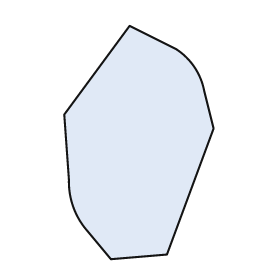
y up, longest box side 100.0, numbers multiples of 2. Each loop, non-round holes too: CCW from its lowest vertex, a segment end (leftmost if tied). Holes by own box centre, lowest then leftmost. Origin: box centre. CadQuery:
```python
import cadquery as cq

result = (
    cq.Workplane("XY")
    .moveTo(-12.0, -50.0)
    .lineTo(12.0, -48.0)
    .lineTo(32.0, 6.0)
    .lineTo(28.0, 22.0)
    .threePointArc((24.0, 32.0), (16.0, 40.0))
    .lineTo(-4.0, 50.0)
    .lineTo(-32.0, 12.0)
    .lineTo(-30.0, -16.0)
    .threePointArc((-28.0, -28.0), (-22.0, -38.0))
    .close()
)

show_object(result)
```